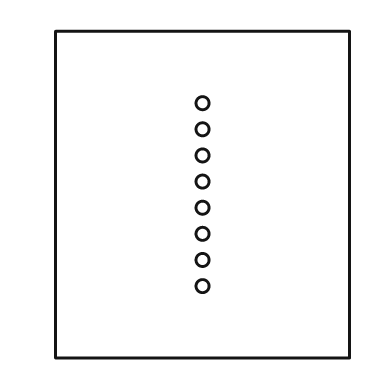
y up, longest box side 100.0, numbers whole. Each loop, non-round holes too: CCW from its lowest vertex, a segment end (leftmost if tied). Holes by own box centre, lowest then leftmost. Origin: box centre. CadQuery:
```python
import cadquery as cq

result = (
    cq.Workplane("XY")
    .moveTo(-45.0, -50.0)
    .lineTo(45.0, -50.0)
    .lineTo(45.0, 50.0)
    .lineTo(-45.0, 50.0)
    .close()
    .moveTo(0.0, -28.0)
    .circle(2.0)
    .moveTo(0.0, -20.0)
    .circle(2.0)
    .moveTo(0.0, -12.0)
    .circle(2.0)
    .moveTo(0.0, -4.0)
    .circle(2.0)
    .moveTo(0.0, 4.0)
    .circle(2.0)
    .moveTo(0.0, 12.0)
    .circle(2.0)
    .moveTo(0.0, 20.0)
    .circle(2.0)
    .moveTo(0.0, 28.0)
    .circle(2.0)
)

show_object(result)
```